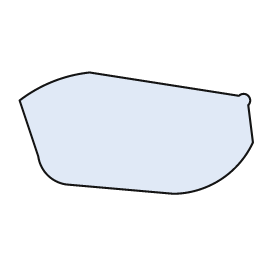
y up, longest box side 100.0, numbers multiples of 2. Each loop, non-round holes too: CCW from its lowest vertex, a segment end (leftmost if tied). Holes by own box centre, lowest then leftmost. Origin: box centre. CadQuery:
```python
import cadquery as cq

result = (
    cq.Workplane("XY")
    .moveTo(16.0, -26.0)
    .threePointArc((36.0, -20.0), (50.0, -4.0))
    .lineTo(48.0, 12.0)
    .threePointArc((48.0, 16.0), (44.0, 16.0))
    .lineTo(-20.0, 26.0)
    .threePointArc((-36.0, 22.0), (-50.0, 14.0))
    .lineTo(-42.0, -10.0)
    .threePointArc((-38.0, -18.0), (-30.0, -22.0))
    .close()
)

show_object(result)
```